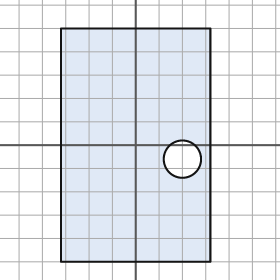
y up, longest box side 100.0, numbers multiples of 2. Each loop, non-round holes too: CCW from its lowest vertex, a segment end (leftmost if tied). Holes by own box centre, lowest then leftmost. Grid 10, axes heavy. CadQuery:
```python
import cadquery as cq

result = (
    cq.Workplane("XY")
    .moveTo(-32.0, -50.0)
    .lineTo(32.0, -50.0)
    .lineTo(32.0, 50.0)
    .lineTo(-32.0, 50.0)
    .close()
    .moveTo(20.0, -6.0)
    .circle(8.0)
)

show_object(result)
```